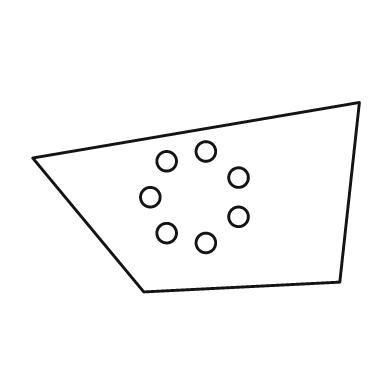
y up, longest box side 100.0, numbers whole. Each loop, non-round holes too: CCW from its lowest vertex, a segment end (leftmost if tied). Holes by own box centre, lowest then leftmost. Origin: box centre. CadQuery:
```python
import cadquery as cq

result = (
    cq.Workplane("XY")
    .moveTo(-16.0, -29.0)
    .lineTo(44.0, -26.0)
    .lineTo(50.0, 29.0)
    .lineTo(-50.0, 12.0)
    .close()
    .moveTo(3.0, -14.0)
    .circle(3.0)
    .moveTo(-9.0, -11.0)
    .circle(3.0)
    .moveTo(13.0, -6.0)
    .circle(3.0)
    .moveTo(-14.0, 0.0)
    .circle(3.0)
    .moveTo(13.0, 6.0)
    .circle(3.0)
    .moveTo(-9.0, 11.0)
    .circle(3.0)
    .moveTo(3.0, 14.0)
    .circle(3.0)
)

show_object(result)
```